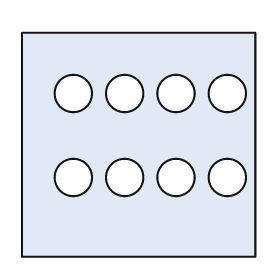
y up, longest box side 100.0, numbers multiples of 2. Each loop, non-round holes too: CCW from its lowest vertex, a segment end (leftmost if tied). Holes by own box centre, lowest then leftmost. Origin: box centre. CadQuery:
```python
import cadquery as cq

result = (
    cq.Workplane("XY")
    .moveTo(-50.0, -48.0)
    .lineTo(50.0, -48.0)
    .lineTo(50.0, 48.0)
    .lineTo(-50.0, 48.0)
    .close()
    .moveTo(-28.0, -14.0)
    .circle(8.0)
    .moveTo(-6.0, -14.0)
    .circle(8.0)
    .moveTo(16.0, -14.0)
    .circle(8.0)
    .moveTo(38.0, -14.0)
    .circle(8.0)
    .moveTo(-28.0, 22.0)
    .circle(8.0)
    .moveTo(-6.0, 22.0)
    .circle(8.0)
    .moveTo(16.0, 22.0)
    .circle(8.0)
    .moveTo(38.0, 22.0)
    .circle(8.0)
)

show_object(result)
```